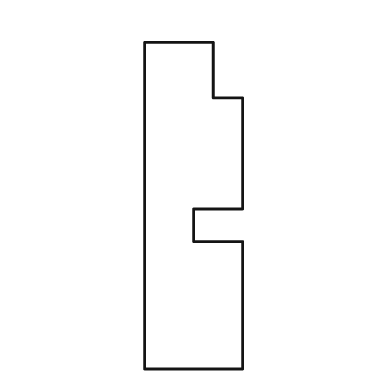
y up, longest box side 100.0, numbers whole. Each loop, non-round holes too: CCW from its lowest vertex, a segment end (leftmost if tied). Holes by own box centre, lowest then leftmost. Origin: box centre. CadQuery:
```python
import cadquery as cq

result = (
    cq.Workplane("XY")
    .moveTo(-15.0, -50.0)
    .lineTo(15.0, -50.0)
    .lineTo(15.0, -11.0)
    .lineTo(0.0, -11.0)
    .lineTo(0.0, -1.0)
    .lineTo(15.0, -1.0)
    .lineTo(15.0, 33.0)
    .lineTo(6.0, 33.0)
    .lineTo(6.0, 50.0)
    .lineTo(-15.0, 50.0)
    .close()
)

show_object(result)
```